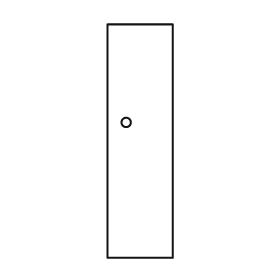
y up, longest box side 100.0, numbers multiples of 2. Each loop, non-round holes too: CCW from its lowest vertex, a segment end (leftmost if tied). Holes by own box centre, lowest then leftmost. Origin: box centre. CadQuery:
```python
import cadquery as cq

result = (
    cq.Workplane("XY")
    .moveTo(-14.0, -50.0)
    .lineTo(14.0, -50.0)
    .lineTo(14.0, 50.0)
    .lineTo(-14.0, 50.0)
    .close()
    .moveTo(-6.0, 8.0)
    .circle(2.0)
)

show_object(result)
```